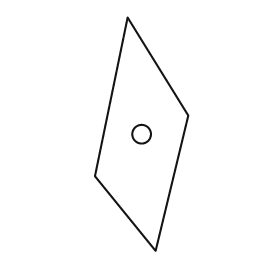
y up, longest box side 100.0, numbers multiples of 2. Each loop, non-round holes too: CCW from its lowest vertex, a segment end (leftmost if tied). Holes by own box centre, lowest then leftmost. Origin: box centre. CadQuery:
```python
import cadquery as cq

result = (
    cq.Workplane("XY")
    .moveTo(6.0, -50.0)
    .lineTo(20.0, 8.0)
    .lineTo(-6.0, 50.0)
    .lineTo(-20.0, -18.0)
    .close()
    .moveTo(0.0, 0.0)
    .circle(4.0)
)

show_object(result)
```